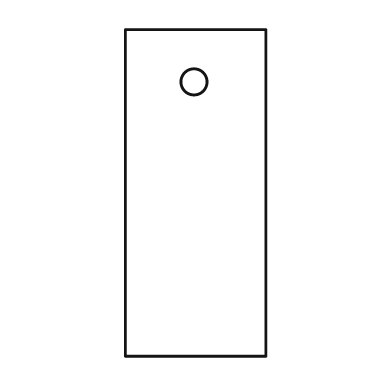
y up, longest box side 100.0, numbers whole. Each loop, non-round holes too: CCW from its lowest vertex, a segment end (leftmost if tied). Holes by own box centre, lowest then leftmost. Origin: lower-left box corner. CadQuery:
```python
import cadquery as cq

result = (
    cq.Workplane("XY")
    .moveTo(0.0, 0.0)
    .lineTo(43.0, 0.0)
    .lineTo(43.0, 100.0)
    .lineTo(0.0, 100.0)
    .close()
    .moveTo(21.0, 84.0)
    .circle(4.0)
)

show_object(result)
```